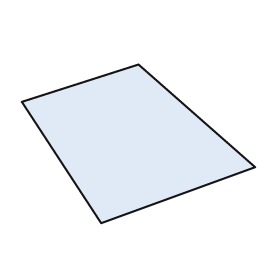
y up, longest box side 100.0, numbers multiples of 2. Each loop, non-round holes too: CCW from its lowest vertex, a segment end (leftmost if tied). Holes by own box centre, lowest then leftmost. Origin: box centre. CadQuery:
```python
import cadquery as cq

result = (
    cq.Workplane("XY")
    .moveTo(-16.0, -34.0)
    .lineTo(50.0, -10.0)
    .lineTo(0.0, 34.0)
    .lineTo(-50.0, 18.0)
    .close()
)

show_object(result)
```